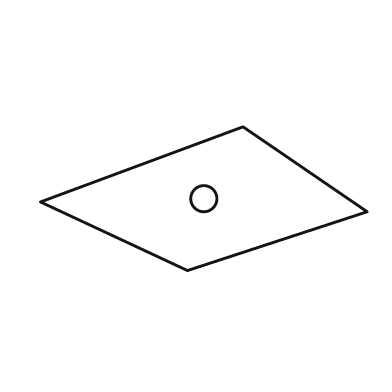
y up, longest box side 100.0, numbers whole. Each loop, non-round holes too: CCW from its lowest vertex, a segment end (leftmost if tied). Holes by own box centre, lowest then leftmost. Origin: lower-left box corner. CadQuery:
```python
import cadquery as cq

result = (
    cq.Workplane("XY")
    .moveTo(45.0, 0.0)
    .lineTo(100.0, 18.0)
    .lineTo(62.0, 44.0)
    .lineTo(0.0, 21.0)
    .close()
    .moveTo(50.0, 22.0)
    .circle(4.0)
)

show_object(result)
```